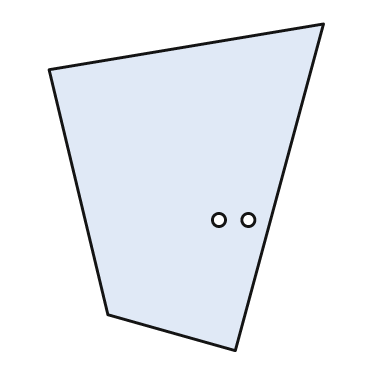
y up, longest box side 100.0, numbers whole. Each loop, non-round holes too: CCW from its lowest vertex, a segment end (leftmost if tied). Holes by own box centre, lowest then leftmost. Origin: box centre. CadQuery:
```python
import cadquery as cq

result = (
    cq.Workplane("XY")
    .moveTo(15.0, -50.0)
    .lineTo(42.0, 50.0)
    .lineTo(-42.0, 36.0)
    .lineTo(-24.0, -39.0)
    .close()
    .moveTo(10.0, -10.0)
    .circle(2.0)
    .moveTo(19.0, -10.0)
    .circle(2.0)
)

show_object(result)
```